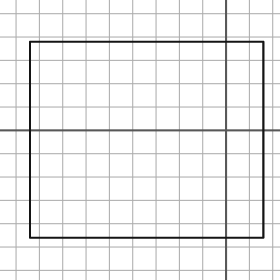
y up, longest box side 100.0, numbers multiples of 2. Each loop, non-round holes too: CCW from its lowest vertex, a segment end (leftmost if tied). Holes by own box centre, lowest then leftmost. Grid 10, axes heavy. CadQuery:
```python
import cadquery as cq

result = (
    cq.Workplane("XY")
    .moveTo(-84.0, -46.0)
    .lineTo(16.0, -46.0)
    .lineTo(16.0, 38.0)
    .lineTo(-84.0, 38.0)
    .close()
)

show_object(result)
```